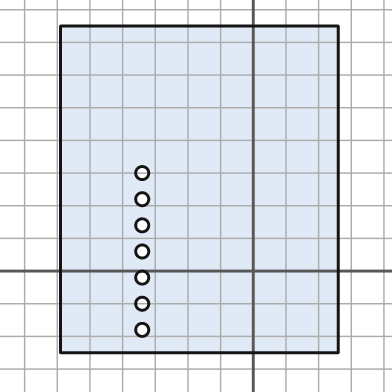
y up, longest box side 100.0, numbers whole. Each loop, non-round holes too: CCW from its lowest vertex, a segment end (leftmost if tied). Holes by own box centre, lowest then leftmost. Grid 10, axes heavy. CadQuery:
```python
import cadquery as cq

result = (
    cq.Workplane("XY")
    .moveTo(-59.0, -25.0)
    .lineTo(26.0, -25.0)
    .lineTo(26.0, 75.0)
    .lineTo(-59.0, 75.0)
    .close()
    .moveTo(-34.0, -18.0)
    .circle(2.0)
    .moveTo(-34.0, -10.0)
    .circle(2.0)
    .moveTo(-34.0, -2.0)
    .circle(2.0)
    .moveTo(-34.0, 6.0)
    .circle(2.0)
    .moveTo(-34.0, 14.0)
    .circle(2.0)
    .moveTo(-34.0, 22.0)
    .circle(2.0)
    .moveTo(-34.0, 30.0)
    .circle(2.0)
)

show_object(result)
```